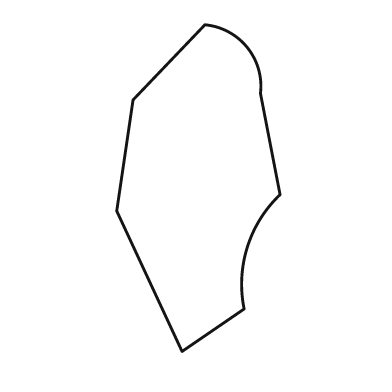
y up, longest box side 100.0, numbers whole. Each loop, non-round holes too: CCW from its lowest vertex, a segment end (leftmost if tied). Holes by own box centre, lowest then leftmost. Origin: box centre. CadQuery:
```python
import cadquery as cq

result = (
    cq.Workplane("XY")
    .moveTo(-5.0, -50.0)
    .lineTo(14.0, -37.0)
    .threePointArc((15.0, -18.0), (25.0, -2.0))
    .lineTo(19.0, 29.0)
    .threePointArc((15.0, 43.0), (2.0, 50.0))
    .lineTo(-20.0, 27.0)
    .lineTo(-25.0, -7.0)
    .close()
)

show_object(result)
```